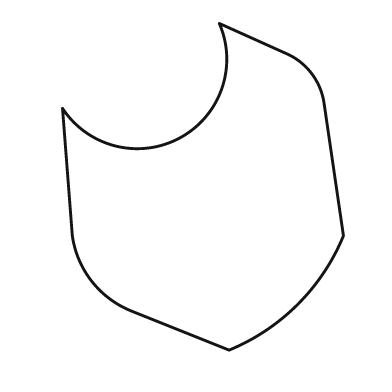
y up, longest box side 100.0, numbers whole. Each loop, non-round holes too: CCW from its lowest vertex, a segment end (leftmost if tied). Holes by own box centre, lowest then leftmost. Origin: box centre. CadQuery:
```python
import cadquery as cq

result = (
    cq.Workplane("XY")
    .moveTo(8.0, -50.0)
    .threePointArc((29.0, -36.0), (43.0, -15.0))
    .lineTo(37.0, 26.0)
    .threePointArc((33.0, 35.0), (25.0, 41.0))
    .lineTo(5.0, 50.0)
    .threePointArc((-7.0, 15.0), (-43.0, 24.0))
    .lineTo(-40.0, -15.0)
    .threePointArc((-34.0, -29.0), (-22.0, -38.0))
    .close()
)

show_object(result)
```